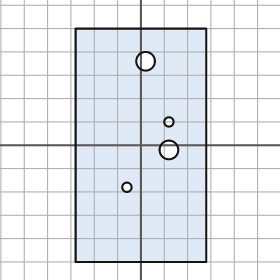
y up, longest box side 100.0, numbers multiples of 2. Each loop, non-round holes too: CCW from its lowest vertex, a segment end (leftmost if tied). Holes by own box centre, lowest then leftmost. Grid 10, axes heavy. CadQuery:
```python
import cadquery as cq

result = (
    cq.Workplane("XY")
    .moveTo(-28.0, -50.0)
    .lineTo(28.0, -50.0)
    .lineTo(28.0, 50.0)
    .lineTo(-28.0, 50.0)
    .close()
    .moveTo(-6.0, -18.0)
    .circle(2.0)
    .moveTo(12.0, -2.0)
    .circle(4.0)
    .moveTo(12.0, 10.0)
    .circle(2.0)
    .moveTo(2.0, 36.0)
    .circle(4.0)
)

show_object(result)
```